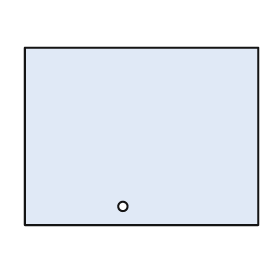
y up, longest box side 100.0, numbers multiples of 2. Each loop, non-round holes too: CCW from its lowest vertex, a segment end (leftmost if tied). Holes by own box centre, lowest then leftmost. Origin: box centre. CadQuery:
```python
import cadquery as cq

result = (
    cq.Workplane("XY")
    .moveTo(-50.0, -38.0)
    .lineTo(50.0, -38.0)
    .lineTo(50.0, 38.0)
    .lineTo(-50.0, 38.0)
    .close()
    .moveTo(-8.0, -30.0)
    .circle(2.0)
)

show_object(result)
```